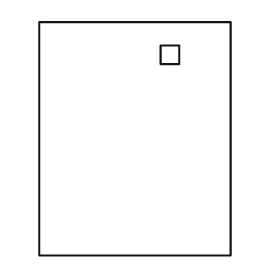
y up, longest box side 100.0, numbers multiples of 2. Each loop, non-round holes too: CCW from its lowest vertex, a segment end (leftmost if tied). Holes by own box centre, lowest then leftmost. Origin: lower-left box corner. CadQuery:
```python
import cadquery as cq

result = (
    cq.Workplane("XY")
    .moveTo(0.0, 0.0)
    .lineTo(82.0, 0.0)
    .lineTo(82.0, 100.0)
    .lineTo(0.0, 100.0)
    .close()
    .moveTo(52.0, 82.0)
    .lineTo(60.0, 82.0)
    .lineTo(60.0, 90.0)
    .lineTo(52.0, 90.0)
    .close()
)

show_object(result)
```